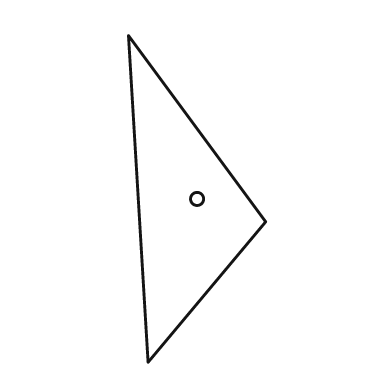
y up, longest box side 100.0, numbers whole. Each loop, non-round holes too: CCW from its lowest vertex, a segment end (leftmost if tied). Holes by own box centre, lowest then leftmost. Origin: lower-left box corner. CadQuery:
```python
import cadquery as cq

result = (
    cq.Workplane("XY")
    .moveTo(6.0, 0.0)
    .lineTo(42.0, 43.0)
    .lineTo(0.0, 100.0)
    .close()
    .moveTo(21.0, 50.0)
    .circle(2.0)
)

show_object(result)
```